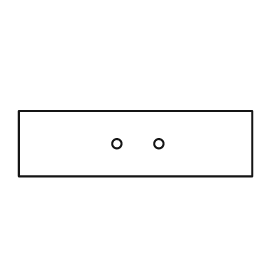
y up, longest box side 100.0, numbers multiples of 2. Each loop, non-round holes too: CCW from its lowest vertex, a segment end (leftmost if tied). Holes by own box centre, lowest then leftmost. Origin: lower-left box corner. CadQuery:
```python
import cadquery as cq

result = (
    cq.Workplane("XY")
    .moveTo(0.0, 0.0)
    .lineTo(100.0, 0.0)
    .lineTo(100.0, 28.0)
    .lineTo(0.0, 28.0)
    .close()
    .moveTo(42.0, 14.0)
    .circle(2.0)
    .moveTo(60.0, 14.0)
    .circle(2.0)
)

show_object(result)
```